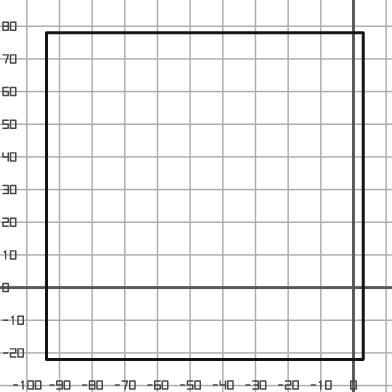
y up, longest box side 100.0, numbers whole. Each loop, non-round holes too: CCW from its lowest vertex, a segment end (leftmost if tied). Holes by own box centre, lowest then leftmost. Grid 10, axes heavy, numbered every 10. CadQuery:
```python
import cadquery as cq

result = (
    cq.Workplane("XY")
    .moveTo(-94.0, -22.0)
    .lineTo(3.0, -22.0)
    .lineTo(3.0, 78.0)
    .lineTo(-94.0, 78.0)
    .close()
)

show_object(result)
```